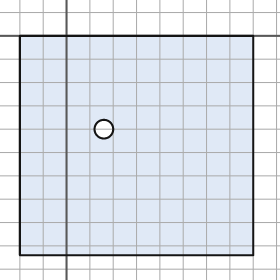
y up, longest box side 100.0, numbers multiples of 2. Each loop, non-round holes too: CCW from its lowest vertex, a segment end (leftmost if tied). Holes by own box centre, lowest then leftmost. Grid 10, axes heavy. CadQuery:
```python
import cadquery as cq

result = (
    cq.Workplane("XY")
    .moveTo(-20.0, -94.0)
    .lineTo(80.0, -94.0)
    .lineTo(80.0, 0.0)
    .lineTo(-20.0, 0.0)
    .close()
    .moveTo(16.0, -40.0)
    .circle(4.0)
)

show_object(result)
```